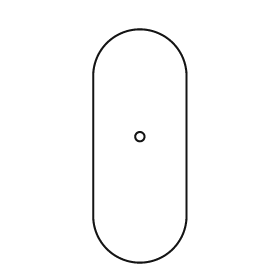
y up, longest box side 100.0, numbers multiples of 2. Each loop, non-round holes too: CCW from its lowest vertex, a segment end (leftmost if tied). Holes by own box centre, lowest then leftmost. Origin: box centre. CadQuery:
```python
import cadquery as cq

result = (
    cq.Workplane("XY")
    .moveTo(-20.0, -30.0)
    .threePointArc((0.0, -50.0), (20.0, -30.0))
    .lineTo(20.0, 30.0)
    .threePointArc((0.0, 50.0), (-20.0, 30.0))
    .close()
    .moveTo(0.0, 4.0)
    .circle(2.0)
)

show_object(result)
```